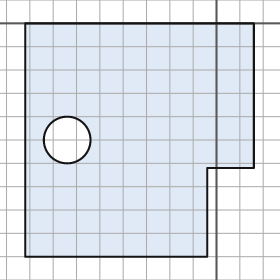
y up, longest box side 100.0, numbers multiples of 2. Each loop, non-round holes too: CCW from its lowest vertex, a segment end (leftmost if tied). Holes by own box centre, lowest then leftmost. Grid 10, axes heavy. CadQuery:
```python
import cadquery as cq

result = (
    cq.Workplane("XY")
    .moveTo(-82.0, -100.0)
    .lineTo(-4.0, -100.0)
    .lineTo(-4.0, -62.0)
    .lineTo(16.0, -62.0)
    .lineTo(16.0, 0.0)
    .lineTo(-82.0, 0.0)
    .close()
    .moveTo(-64.0, -50.0)
    .circle(10.0)
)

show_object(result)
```